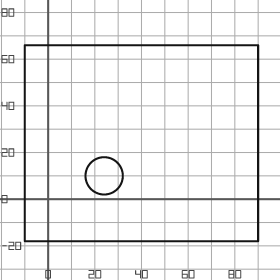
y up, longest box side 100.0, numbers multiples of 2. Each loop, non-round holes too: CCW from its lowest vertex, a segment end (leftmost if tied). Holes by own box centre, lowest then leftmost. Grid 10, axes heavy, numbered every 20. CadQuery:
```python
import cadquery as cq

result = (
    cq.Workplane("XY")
    .moveTo(-10.0, -18.0)
    .lineTo(90.0, -18.0)
    .lineTo(90.0, 66.0)
    .lineTo(-10.0, 66.0)
    .close()
    .moveTo(24.0, 10.0)
    .circle(8.0)
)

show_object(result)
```